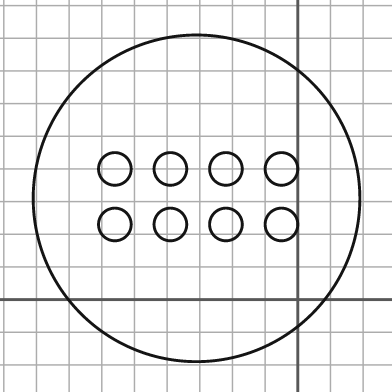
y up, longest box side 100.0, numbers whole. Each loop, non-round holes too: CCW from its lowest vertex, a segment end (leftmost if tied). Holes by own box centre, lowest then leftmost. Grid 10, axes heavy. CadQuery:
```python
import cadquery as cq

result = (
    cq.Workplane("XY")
    .moveTo(-31.0, 31.0)
    .circle(50.0)
    .moveTo(-56.0, 23.0)
    .circle(5.0)
    .moveTo(-39.0, 23.0)
    .circle(5.0)
    .moveTo(-22.0, 23.0)
    .circle(5.0)
    .moveTo(-5.0, 23.0)
    .circle(5.0)
    .moveTo(-56.0, 40.0)
    .circle(5.0)
    .moveTo(-39.0, 40.0)
    .circle(5.0)
    .moveTo(-22.0, 40.0)
    .circle(5.0)
    .moveTo(-5.0, 40.0)
    .circle(5.0)
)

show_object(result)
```